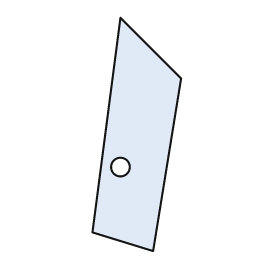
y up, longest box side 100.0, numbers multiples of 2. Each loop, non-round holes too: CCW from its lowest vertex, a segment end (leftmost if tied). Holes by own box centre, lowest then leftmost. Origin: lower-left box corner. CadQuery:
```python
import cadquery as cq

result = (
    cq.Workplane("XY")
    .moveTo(26.0, 0.0)
    .lineTo(38.0, 74.0)
    .lineTo(12.0, 100.0)
    .lineTo(0.0, 8.0)
    .close()
    .moveTo(12.0, 36.0)
    .circle(4.0)
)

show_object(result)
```